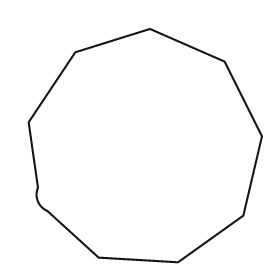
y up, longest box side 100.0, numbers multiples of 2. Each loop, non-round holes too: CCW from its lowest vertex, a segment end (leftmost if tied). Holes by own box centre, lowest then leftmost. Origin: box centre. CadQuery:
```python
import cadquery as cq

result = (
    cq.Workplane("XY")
    .moveTo(14.0, -50.0)
    .lineTo(42.0, -30.0)
    .lineTo(50.0, 4.0)
    .lineTo(34.0, 36.0)
    .lineTo(2.0, 50.0)
    .lineTo(-30.0, 40.0)
    .lineTo(-50.0, 10.0)
    .lineTo(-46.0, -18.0)
    .threePointArc((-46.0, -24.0), (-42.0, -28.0))
    .lineTo(-20.0, -48.0)
    .close()
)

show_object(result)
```